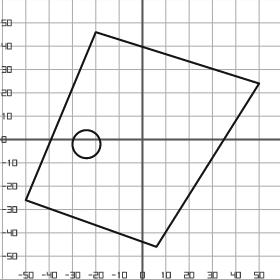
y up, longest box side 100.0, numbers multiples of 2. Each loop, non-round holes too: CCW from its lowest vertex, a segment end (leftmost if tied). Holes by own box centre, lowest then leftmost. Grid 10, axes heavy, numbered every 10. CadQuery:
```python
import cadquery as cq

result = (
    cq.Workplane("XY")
    .moveTo(6.0, -46.0)
    .lineTo(50.0, 24.0)
    .lineTo(-20.0, 46.0)
    .lineTo(-50.0, -26.0)
    .close()
    .moveTo(-24.0, -2.0)
    .circle(6.0)
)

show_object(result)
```